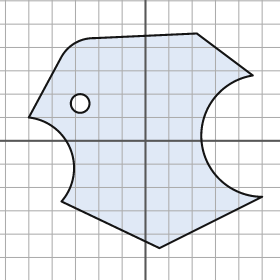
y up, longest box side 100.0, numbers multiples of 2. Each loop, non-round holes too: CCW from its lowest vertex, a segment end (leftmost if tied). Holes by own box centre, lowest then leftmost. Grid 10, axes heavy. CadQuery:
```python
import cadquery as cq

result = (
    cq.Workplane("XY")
    .moveTo(6.0, -46.0)
    .lineTo(50.0, -24.0)
    .threePointArc((24.0, 0.0), (46.0, 28.0))
    .lineTo(22.0, 46.0)
    .lineTo(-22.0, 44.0)
    .threePointArc((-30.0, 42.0), (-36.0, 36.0))
    .lineTo(-50.0, 10.0)
    .threePointArc((-32.0, -4.0), (-36.0, -26.0))
    .close()
    .moveTo(-28.0, 16.0)
    .circle(4.0)
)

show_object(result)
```